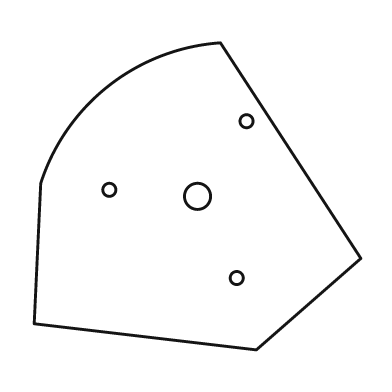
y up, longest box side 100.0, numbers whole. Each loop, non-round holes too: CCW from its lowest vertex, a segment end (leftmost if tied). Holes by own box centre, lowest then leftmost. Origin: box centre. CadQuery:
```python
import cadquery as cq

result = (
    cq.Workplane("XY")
    .moveTo(18.0, -47.0)
    .lineTo(50.0, -19.0)
    .lineTo(7.0, 47.0)
    .threePointArc((-27.0, 34.0), (-48.0, 4.0))
    .lineTo(-50.0, -39.0)
    .close()
    .moveTo(12.0, -25.0)
    .circle(2.0)
    .moveTo(0.0, 0.0)
    .circle(4.0)
    .moveTo(-27.0, 2.0)
    .circle(2.0)
    .moveTo(15.0, 23.0)
    .circle(2.0)
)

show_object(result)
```